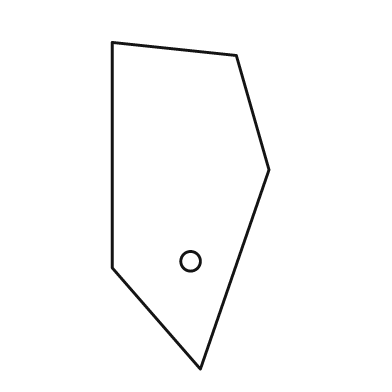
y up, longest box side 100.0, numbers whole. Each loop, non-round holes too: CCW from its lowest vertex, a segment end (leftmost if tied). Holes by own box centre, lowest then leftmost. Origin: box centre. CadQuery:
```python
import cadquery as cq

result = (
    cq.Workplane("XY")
    .moveTo(3.0, -50.0)
    .lineTo(24.0, 11.0)
    .lineTo(14.0, 46.0)
    .lineTo(-24.0, 50.0)
    .lineTo(-24.0, -19.0)
    .close()
    .moveTo(0.0, -17.0)
    .circle(3.0)
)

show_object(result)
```